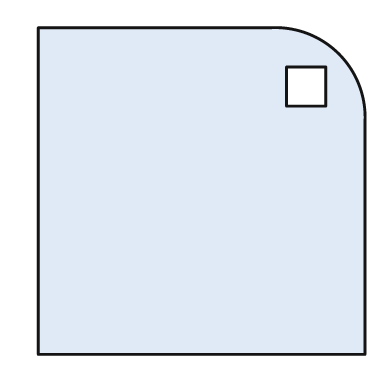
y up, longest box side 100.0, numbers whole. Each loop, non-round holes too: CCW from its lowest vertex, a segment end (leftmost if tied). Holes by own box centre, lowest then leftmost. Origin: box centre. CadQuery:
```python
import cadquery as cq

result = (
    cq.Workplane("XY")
    .moveTo(-50.0, -50.0)
    .lineTo(50.0, -50.0)
    .lineTo(50.0, 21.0)
    .threePointArc((42.0, 42.0), (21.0, 50.0))
    .lineTo(-50.0, 50.0)
    .close()
    .moveTo(26.0, 26.0)
    .lineTo(38.0, 26.0)
    .lineTo(38.0, 38.0)
    .lineTo(26.0, 38.0)
    .close()
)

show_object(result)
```